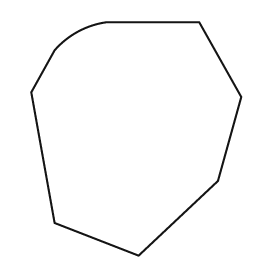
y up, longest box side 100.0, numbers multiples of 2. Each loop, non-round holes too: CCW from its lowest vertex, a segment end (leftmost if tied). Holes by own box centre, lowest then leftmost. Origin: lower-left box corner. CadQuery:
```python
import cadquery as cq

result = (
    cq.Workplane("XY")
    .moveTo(46.0, 0.0)
    .lineTo(80.0, 32.0)
    .lineTo(90.0, 68.0)
    .lineTo(72.0, 100.0)
    .lineTo(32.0, 100.0)
    .threePointArc((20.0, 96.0), (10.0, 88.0))
    .lineTo(0.0, 70.0)
    .lineTo(10.0, 14.0)
    .close()
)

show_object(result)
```